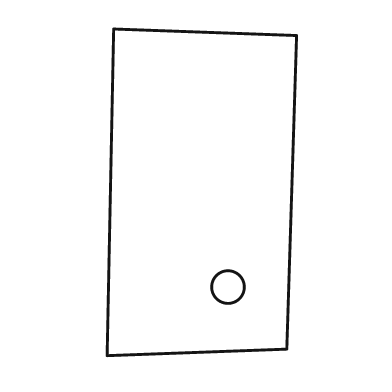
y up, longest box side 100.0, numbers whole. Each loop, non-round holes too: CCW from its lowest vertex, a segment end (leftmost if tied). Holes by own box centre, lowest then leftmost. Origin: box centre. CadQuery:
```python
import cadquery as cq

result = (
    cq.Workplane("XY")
    .moveTo(-29.0, -50.0)
    .lineTo(26.0, -48.0)
    .lineTo(29.0, 48.0)
    .lineTo(-27.0, 50.0)
    .close()
    .moveTo(8.0, -29.0)
    .circle(5.0)
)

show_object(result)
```